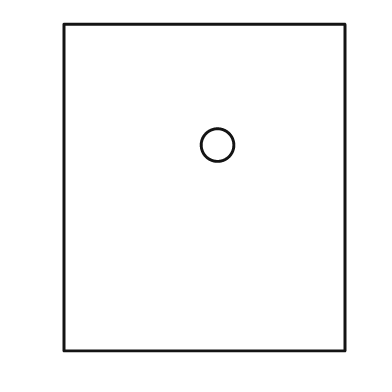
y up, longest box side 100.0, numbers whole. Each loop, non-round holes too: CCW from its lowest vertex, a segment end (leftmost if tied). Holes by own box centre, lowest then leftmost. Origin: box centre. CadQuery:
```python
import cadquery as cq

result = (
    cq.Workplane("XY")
    .moveTo(-43.0, -50.0)
    .lineTo(43.0, -50.0)
    .lineTo(43.0, 50.0)
    .lineTo(-43.0, 50.0)
    .close()
    .moveTo(4.0, 13.0)
    .circle(5.0)
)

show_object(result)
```